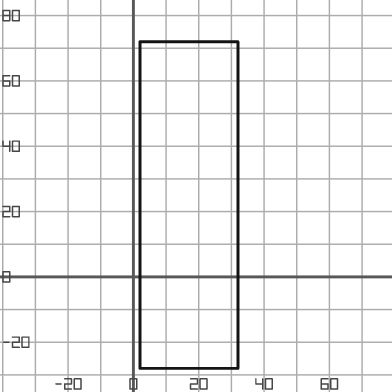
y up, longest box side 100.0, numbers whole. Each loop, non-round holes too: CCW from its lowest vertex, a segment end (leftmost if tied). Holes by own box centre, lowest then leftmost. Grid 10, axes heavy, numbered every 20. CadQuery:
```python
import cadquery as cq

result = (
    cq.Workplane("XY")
    .moveTo(2.0, -28.0)
    .lineTo(32.0, -28.0)
    .lineTo(32.0, 72.0)
    .lineTo(2.0, 72.0)
    .close()
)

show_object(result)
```